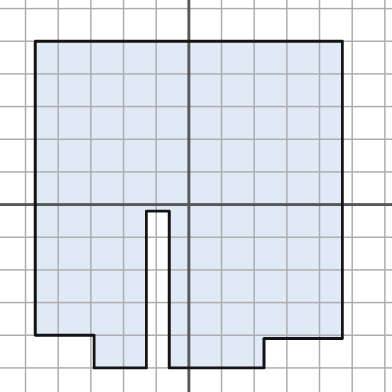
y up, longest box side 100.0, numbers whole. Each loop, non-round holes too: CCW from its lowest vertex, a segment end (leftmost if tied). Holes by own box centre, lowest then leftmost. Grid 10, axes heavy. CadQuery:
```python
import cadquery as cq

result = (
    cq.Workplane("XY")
    .moveTo(-29.0, -50.0)
    .lineTo(-13.0, -50.0)
    .lineTo(-13.0, -2.0)
    .lineTo(-6.0, -2.0)
    .lineTo(-6.0, -50.0)
    .lineTo(23.0, -50.0)
    .lineTo(23.0, -41.0)
    .lineTo(47.0, -41.0)
    .lineTo(47.0, 50.0)
    .lineTo(-47.0, 50.0)
    .lineTo(-47.0, -40.0)
    .lineTo(-29.0, -40.0)
    .close()
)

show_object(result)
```